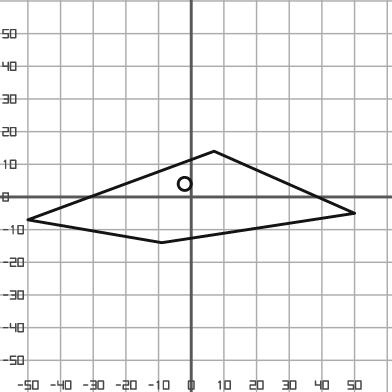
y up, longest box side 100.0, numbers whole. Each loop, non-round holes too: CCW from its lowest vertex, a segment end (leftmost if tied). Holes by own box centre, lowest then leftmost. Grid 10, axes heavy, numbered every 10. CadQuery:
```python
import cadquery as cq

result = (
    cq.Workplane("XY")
    .moveTo(-9.0, -14.0)
    .lineTo(50.0, -5.0)
    .lineTo(7.0, 14.0)
    .lineTo(-50.0, -7.0)
    .close()
    .moveTo(-2.0, 4.0)
    .circle(2.0)
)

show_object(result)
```